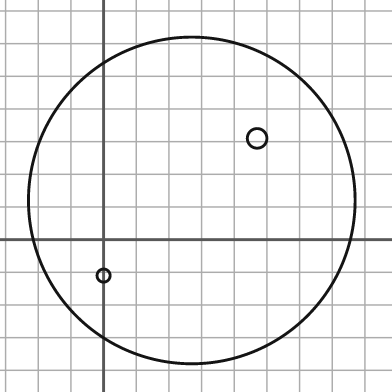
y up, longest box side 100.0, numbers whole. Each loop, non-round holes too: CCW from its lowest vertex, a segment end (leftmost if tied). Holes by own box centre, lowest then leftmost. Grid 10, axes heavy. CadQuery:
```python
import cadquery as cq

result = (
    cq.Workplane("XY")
    .moveTo(27.0, 12.0)
    .circle(50.0)
    .moveTo(0.0, -11.0)
    .circle(2.0)
    .moveTo(47.0, 31.0)
    .circle(3.0)
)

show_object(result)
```